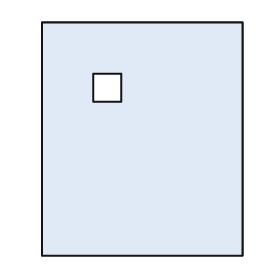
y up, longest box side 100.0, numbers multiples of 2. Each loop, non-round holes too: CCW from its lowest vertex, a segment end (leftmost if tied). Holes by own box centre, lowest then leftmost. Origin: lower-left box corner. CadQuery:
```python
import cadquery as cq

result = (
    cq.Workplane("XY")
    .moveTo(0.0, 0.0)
    .lineTo(86.0, 0.0)
    .lineTo(86.0, 100.0)
    .lineTo(0.0, 100.0)
    .close()
    .moveTo(22.0, 66.0)
    .lineTo(34.0, 66.0)
    .lineTo(34.0, 78.0)
    .lineTo(22.0, 78.0)
    .close()
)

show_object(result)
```